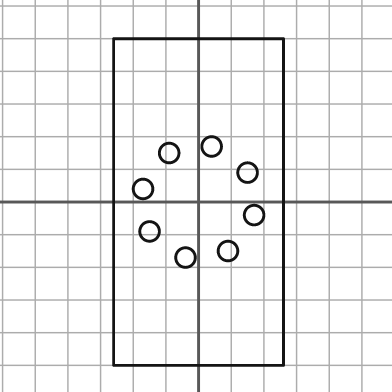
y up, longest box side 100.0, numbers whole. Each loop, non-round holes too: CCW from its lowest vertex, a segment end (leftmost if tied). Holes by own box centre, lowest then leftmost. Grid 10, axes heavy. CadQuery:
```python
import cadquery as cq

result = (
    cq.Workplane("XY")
    .moveTo(-26.0, -50.0)
    .lineTo(26.0, -50.0)
    .lineTo(26.0, 50.0)
    .lineTo(-26.0, 50.0)
    .close()
    .moveTo(-4.0, -17.0)
    .circle(3.0)
    .moveTo(9.0, -15.0)
    .circle(3.0)
    .moveTo(-15.0, -9.0)
    .circle(3.0)
    .moveTo(17.0, -4.0)
    .circle(3.0)
    .moveTo(-17.0, 4.0)
    .circle(3.0)
    .moveTo(15.0, 9.0)
    .circle(3.0)
    .moveTo(-9.0, 15.0)
    .circle(3.0)
    .moveTo(4.0, 17.0)
    .circle(3.0)
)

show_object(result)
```